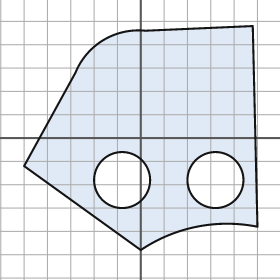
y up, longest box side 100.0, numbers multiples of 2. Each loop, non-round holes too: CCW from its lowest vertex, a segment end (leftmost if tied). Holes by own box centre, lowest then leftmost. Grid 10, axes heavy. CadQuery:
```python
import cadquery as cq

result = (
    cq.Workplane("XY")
    .moveTo(0.0, -48.0)
    .threePointArc((24.0, -38.0), (50.0, -38.0))
    .lineTo(48.0, 48.0)
    .lineTo(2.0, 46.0)
    .threePointArc((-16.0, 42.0), (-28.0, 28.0))
    .lineTo(-50.0, -12.0)
    .close()
    .moveTo(-8.0, -18.0)
    .circle(12.0)
    .moveTo(32.0, -18.0)
    .circle(12.0)
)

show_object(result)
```